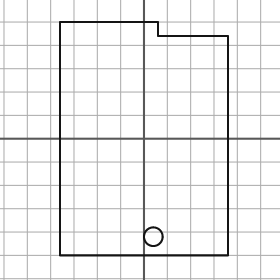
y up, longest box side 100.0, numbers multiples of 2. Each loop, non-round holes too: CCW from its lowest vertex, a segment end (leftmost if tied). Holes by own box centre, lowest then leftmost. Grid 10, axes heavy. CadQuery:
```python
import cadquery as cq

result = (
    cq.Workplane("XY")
    .moveTo(-36.0, -50.0)
    .lineTo(36.0, -50.0)
    .lineTo(36.0, 44.0)
    .lineTo(6.0, 44.0)
    .lineTo(6.0, 50.0)
    .lineTo(-36.0, 50.0)
    .close()
    .moveTo(4.0, -42.0)
    .circle(4.0)
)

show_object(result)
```